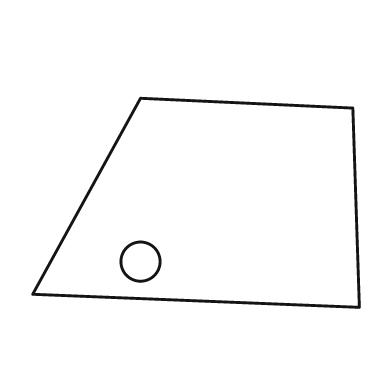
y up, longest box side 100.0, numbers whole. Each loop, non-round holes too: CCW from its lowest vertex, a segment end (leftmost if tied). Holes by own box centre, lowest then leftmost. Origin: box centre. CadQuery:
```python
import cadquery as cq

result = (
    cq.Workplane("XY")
    .moveTo(50.0, -32.0)
    .lineTo(48.0, 29.0)
    .lineTo(-17.0, 32.0)
    .lineTo(-50.0, -28.0)
    .close()
    .moveTo(-17.0, -18.0)
    .circle(6.0)
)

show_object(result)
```